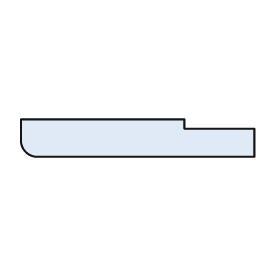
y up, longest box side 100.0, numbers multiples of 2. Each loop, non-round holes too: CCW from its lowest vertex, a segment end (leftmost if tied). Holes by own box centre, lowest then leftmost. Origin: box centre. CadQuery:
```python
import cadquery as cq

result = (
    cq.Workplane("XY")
    .moveTo(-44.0, -8.0)
    .lineTo(50.0, -8.0)
    .lineTo(50.0, 4.0)
    .lineTo(20.0, 4.0)
    .lineTo(20.0, 8.0)
    .lineTo(-50.0, 8.0)
    .lineTo(-50.0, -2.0)
    .threePointArc((-48.0, -6.0), (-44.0, -8.0))
    .close()
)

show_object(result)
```